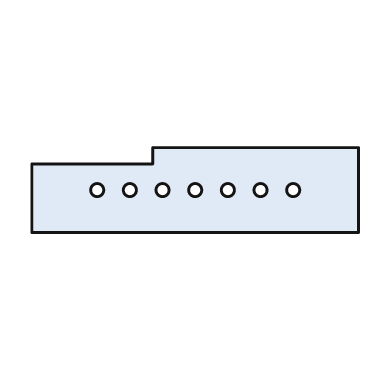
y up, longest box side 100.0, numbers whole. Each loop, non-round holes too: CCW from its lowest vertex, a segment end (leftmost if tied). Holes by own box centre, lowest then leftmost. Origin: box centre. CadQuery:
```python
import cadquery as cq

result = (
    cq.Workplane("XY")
    .moveTo(-50.0, -13.0)
    .lineTo(50.0, -13.0)
    .lineTo(50.0, 13.0)
    .lineTo(-13.0, 13.0)
    .lineTo(-13.0, 8.0)
    .lineTo(-50.0, 8.0)
    .close()
    .moveTo(-30.0, 0.0)
    .circle(2.0)
    .moveTo(-20.0, 0.0)
    .circle(2.0)
    .moveTo(-10.0, 0.0)
    .circle(2.0)
    .moveTo(0.0, 0.0)
    .circle(2.0)
    .moveTo(10.0, 0.0)
    .circle(2.0)
    .moveTo(20.0, 0.0)
    .circle(2.0)
    .moveTo(30.0, 0.0)
    .circle(2.0)
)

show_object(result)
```